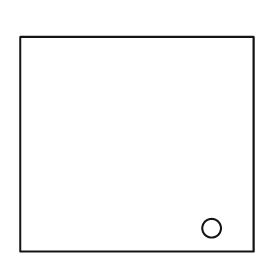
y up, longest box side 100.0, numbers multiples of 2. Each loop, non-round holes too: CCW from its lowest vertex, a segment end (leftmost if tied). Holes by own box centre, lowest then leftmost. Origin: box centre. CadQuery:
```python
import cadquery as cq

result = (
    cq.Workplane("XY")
    .moveTo(-50.0, -46.0)
    .lineTo(50.0, -46.0)
    .lineTo(50.0, 46.0)
    .lineTo(-50.0, 46.0)
    .close()
    .moveTo(32.0, -36.0)
    .circle(4.0)
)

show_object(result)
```